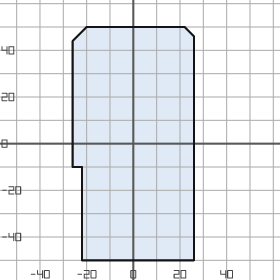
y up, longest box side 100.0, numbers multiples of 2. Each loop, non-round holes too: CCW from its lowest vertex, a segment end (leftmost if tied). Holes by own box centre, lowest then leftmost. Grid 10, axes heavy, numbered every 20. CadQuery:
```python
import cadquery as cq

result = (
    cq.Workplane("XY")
    .moveTo(-22.0, -50.0)
    .lineTo(26.0, -50.0)
    .lineTo(26.0, 46.0)
    .lineTo(22.0, 50.0)
    .lineTo(-20.0, 50.0)
    .lineTo(-26.0, 44.0)
    .lineTo(-26.0, -10.0)
    .lineTo(-22.0, -10.0)
    .close()
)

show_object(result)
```